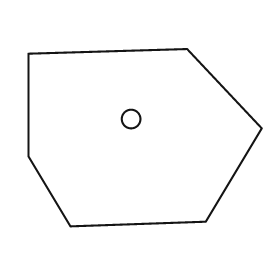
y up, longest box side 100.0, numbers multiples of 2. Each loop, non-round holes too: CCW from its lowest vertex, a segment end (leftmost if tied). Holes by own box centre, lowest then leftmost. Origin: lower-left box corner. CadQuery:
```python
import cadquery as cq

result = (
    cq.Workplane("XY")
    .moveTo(18.0, 0.0)
    .lineTo(76.0, 2.0)
    .lineTo(100.0, 42.0)
    .lineTo(68.0, 76.0)
    .lineTo(0.0, 74.0)
    .lineTo(0.0, 30.0)
    .close()
    .moveTo(44.0, 46.0)
    .circle(4.0)
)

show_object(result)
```